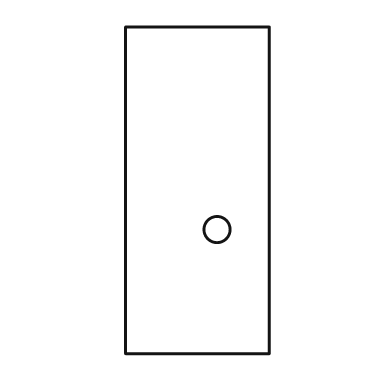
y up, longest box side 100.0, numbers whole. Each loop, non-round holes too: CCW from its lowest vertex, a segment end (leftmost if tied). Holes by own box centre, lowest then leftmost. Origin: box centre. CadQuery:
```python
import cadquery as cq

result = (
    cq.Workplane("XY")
    .moveTo(-22.0, -50.0)
    .lineTo(22.0, -50.0)
    .lineTo(22.0, 50.0)
    .lineTo(-22.0, 50.0)
    .close()
    .moveTo(6.0, -12.0)
    .circle(4.0)
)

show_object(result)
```